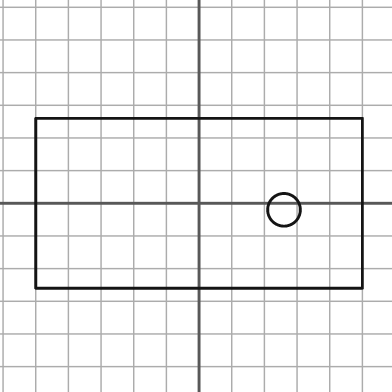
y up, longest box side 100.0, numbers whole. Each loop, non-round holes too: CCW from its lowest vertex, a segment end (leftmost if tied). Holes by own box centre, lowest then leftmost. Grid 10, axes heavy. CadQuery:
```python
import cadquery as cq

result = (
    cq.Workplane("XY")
    .moveTo(-50.0, -26.0)
    .lineTo(50.0, -26.0)
    .lineTo(50.0, 26.0)
    .lineTo(-50.0, 26.0)
    .close()
    .moveTo(26.0, -2.0)
    .circle(5.0)
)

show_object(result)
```